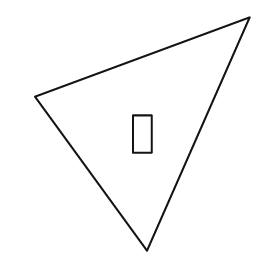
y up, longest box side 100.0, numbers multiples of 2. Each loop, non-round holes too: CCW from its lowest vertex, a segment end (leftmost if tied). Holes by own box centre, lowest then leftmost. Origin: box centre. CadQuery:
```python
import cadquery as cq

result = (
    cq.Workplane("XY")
    .moveTo(2.0, -50.0)
    .lineTo(46.0, 50.0)
    .lineTo(-46.0, 16.0)
    .close()
    .moveTo(-4.0, -8.0)
    .lineTo(4.0, -8.0)
    .lineTo(4.0, 8.0)
    .lineTo(-4.0, 8.0)
    .close()
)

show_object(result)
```